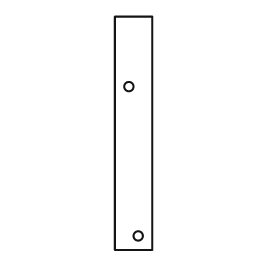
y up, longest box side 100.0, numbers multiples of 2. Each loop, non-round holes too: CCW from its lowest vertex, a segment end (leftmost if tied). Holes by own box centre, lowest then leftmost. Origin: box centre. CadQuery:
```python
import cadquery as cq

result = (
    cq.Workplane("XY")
    .moveTo(-8.0, -50.0)
    .lineTo(8.0, -50.0)
    .lineTo(8.0, 50.0)
    .lineTo(-8.0, 50.0)
    .close()
    .moveTo(2.0, -44.0)
    .circle(2.0)
    .moveTo(-2.0, 20.0)
    .circle(2.0)
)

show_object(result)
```